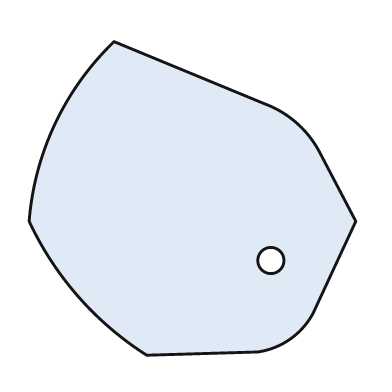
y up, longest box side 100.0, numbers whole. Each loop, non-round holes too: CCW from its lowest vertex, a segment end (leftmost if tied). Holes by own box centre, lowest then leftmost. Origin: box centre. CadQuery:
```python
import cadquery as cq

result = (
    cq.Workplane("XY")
    .moveTo(-14.0, -48.0)
    .lineTo(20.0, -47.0)
    .threePointArc((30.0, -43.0), (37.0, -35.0))
    .lineTo(50.0, -7.0)
    .lineTo(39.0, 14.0)
    .threePointArc((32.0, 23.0), (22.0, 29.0))
    .lineTo(-24.0, 48.0)
    .threePointArc((-42.0, 23.0), (-50.0, -7.0))
    .threePointArc((-35.0, -30.0), (-14.0, -48.0))
    .close()
    .moveTo(24.0, -19.0)
    .circle(4.0)
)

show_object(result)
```